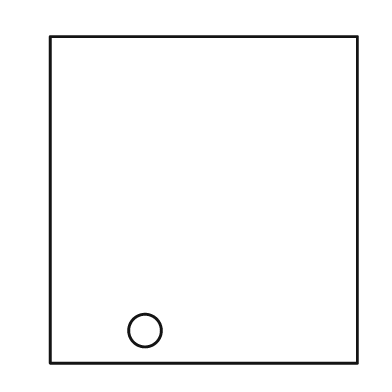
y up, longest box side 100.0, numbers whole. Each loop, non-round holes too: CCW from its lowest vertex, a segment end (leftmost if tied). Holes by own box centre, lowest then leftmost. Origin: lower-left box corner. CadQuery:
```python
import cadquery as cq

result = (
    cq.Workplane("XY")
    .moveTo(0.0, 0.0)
    .lineTo(94.0, 0.0)
    .lineTo(94.0, 100.0)
    .lineTo(0.0, 100.0)
    .close()
    .moveTo(29.0, 10.0)
    .circle(5.0)
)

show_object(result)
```